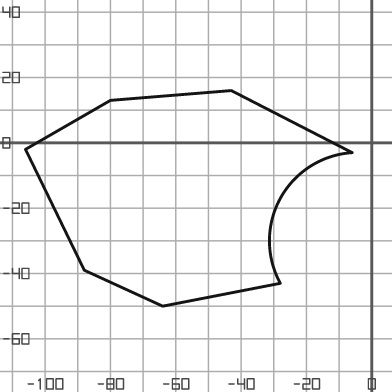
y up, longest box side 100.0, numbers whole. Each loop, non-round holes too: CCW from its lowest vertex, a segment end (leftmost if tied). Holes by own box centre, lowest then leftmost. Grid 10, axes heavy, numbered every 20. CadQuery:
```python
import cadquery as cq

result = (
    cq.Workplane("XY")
    .moveTo(-64.0, -50.0)
    .lineTo(-28.0, -43.0)
    .threePointArc((-28.0, -17.0), (-6.0, -3.0))
    .lineTo(-43.0, 16.0)
    .lineTo(-80.0, 13.0)
    .lineTo(-106.0, -2.0)
    .lineTo(-88.0, -39.0)
    .close()
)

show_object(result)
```